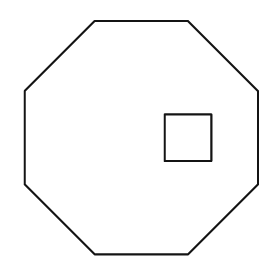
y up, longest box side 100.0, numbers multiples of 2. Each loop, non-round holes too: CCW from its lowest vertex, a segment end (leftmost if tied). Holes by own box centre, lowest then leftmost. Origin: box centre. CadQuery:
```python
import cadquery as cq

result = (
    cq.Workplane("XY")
    .moveTo(-20.0, -50.0)
    .lineTo(20.0, -50.0)
    .lineTo(50.0, -20.0)
    .lineTo(50.0, 20.0)
    .lineTo(20.0, 50.0)
    .lineTo(-20.0, 50.0)
    .lineTo(-50.0, 20.0)
    .lineTo(-50.0, -20.0)
    .close()
    .moveTo(10.0, -10.0)
    .lineTo(30.0, -10.0)
    .lineTo(30.0, 10.0)
    .lineTo(10.0, 10.0)
    .close()
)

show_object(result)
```